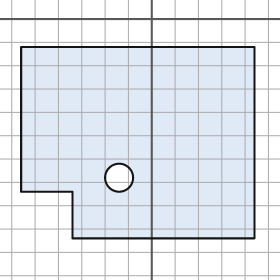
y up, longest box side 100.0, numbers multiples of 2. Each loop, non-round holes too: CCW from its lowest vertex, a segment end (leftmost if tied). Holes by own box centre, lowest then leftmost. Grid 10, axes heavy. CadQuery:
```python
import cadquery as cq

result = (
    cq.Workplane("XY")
    .moveTo(-34.0, -94.0)
    .lineTo(44.0, -94.0)
    .lineTo(44.0, -12.0)
    .lineTo(-56.0, -12.0)
    .lineTo(-56.0, -74.0)
    .lineTo(-34.0, -74.0)
    .close()
    .moveTo(-14.0, -68.0)
    .circle(6.0)
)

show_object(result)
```